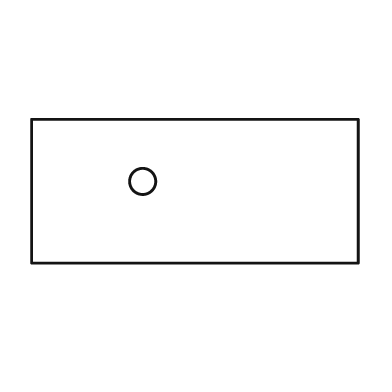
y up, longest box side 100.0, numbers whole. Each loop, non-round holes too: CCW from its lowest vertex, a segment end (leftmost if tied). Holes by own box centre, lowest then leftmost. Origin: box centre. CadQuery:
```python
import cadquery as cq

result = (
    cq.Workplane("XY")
    .moveTo(-50.0, -22.0)
    .lineTo(50.0, -22.0)
    .lineTo(50.0, 22.0)
    .lineTo(-50.0, 22.0)
    .close()
    .moveTo(-16.0, 3.0)
    .circle(4.0)
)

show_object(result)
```